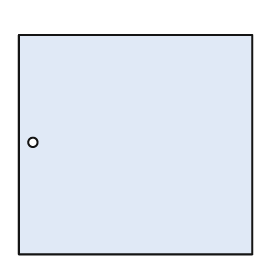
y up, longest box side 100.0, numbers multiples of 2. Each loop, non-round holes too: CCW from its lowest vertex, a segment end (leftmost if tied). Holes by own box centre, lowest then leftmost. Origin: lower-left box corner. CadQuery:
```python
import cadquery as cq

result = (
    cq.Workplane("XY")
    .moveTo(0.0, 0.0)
    .lineTo(100.0, 0.0)
    .lineTo(100.0, 94.0)
    .lineTo(0.0, 94.0)
    .close()
    .moveTo(6.0, 48.0)
    .circle(2.0)
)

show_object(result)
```